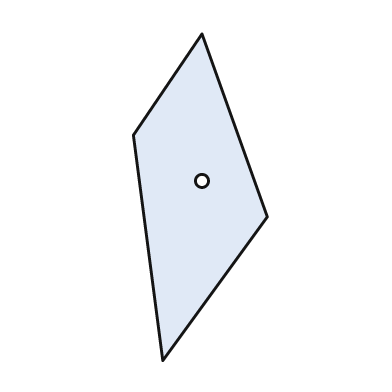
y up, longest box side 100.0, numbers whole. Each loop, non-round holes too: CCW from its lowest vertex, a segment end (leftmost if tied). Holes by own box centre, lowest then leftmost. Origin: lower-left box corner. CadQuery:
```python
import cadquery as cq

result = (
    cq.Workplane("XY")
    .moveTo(9.0, 0.0)
    .lineTo(41.0, 44.0)
    .lineTo(21.0, 100.0)
    .lineTo(0.0, 69.0)
    .close()
    .moveTo(21.0, 55.0)
    .circle(2.0)
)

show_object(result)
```